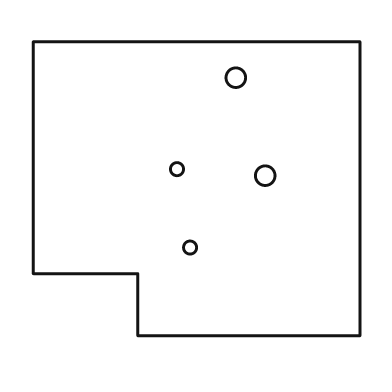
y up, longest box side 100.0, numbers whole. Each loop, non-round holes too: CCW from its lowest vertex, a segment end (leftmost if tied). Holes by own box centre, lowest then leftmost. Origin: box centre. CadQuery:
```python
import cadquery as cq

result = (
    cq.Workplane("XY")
    .moveTo(-18.0, -45.0)
    .lineTo(50.0, -45.0)
    .lineTo(50.0, 45.0)
    .lineTo(-50.0, 45.0)
    .lineTo(-50.0, -26.0)
    .lineTo(-18.0, -26.0)
    .close()
    .moveTo(-2.0, -18.0)
    .circle(2.0)
    .moveTo(21.0, 4.0)
    .circle(3.0)
    .moveTo(-6.0, 6.0)
    .circle(2.0)
    .moveTo(12.0, 34.0)
    .circle(3.0)
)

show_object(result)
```